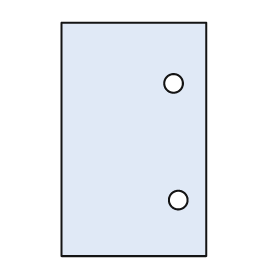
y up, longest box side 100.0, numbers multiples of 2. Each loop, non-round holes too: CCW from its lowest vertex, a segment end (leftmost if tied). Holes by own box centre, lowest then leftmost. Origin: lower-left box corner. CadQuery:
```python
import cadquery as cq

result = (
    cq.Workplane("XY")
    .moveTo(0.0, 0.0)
    .lineTo(62.0, 0.0)
    .lineTo(62.0, 100.0)
    .lineTo(0.0, 100.0)
    .close()
    .moveTo(50.0, 24.0)
    .circle(4.0)
    .moveTo(48.0, 74.0)
    .circle(4.0)
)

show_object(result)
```